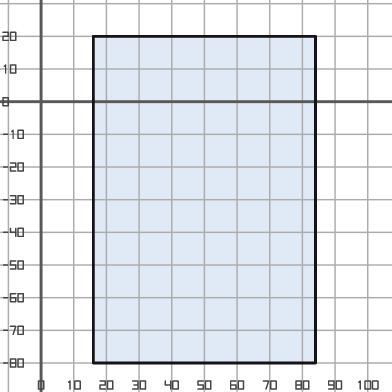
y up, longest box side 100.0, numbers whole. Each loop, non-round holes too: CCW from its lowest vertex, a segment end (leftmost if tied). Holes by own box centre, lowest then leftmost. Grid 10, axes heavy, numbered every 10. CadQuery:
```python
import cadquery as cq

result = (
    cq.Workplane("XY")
    .moveTo(16.0, -80.0)
    .lineTo(84.0, -80.0)
    .lineTo(84.0, 20.0)
    .lineTo(16.0, 20.0)
    .close()
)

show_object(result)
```